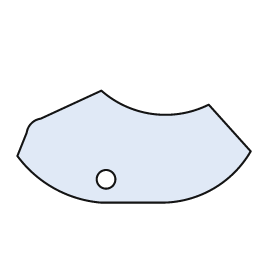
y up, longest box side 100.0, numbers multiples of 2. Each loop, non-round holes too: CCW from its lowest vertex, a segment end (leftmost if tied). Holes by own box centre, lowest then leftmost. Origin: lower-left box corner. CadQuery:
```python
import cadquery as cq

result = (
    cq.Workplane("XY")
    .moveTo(36.0, 0.0)
    .lineTo(62.0, 0.0)
    .threePointArc((84.0, 6.0), (100.0, 22.0))
    .lineTo(82.0, 42.0)
    .threePointArc((58.0, 38.0), (36.0, 48.0))
    .lineTo(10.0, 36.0)
    .threePointArc((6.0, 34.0), (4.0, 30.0))
    .lineTo(0.0, 20.0)
    .threePointArc((16.0, 6.0), (36.0, 0.0))
    .close()
    .moveTo(38.0, 10.0)
    .circle(4.0)
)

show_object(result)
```